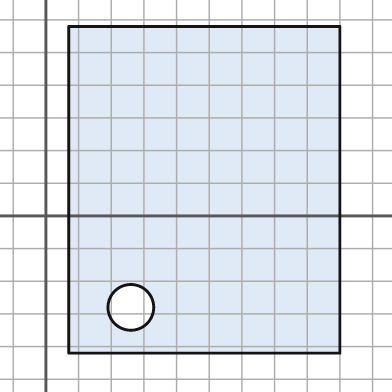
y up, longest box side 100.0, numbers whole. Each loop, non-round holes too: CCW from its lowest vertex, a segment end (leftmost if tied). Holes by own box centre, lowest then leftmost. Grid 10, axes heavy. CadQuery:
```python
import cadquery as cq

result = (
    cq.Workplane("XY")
    .moveTo(7.0, -42.0)
    .lineTo(90.0, -42.0)
    .lineTo(90.0, 58.0)
    .lineTo(7.0, 58.0)
    .close()
    .moveTo(26.0, -28.0)
    .circle(7.0)
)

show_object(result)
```